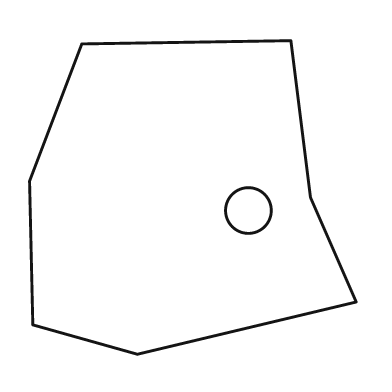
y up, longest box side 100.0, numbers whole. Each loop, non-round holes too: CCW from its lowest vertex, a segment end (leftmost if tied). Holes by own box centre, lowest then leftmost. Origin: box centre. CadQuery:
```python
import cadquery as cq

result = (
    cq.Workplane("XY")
    .moveTo(-17.0, -48.0)
    .lineTo(50.0, -32.0)
    .lineTo(36.0, 0.0)
    .lineTo(30.0, 48.0)
    .lineTo(-34.0, 47.0)
    .lineTo(-50.0, 5.0)
    .lineTo(-49.0, -39.0)
    .close()
    .moveTo(17.0, -4.0)
    .circle(7.0)
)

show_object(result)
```